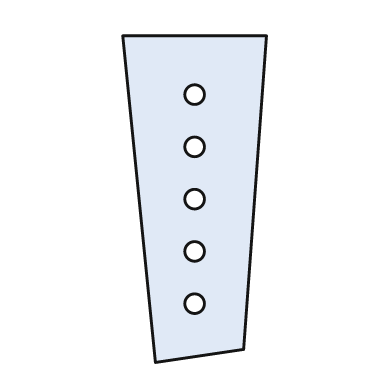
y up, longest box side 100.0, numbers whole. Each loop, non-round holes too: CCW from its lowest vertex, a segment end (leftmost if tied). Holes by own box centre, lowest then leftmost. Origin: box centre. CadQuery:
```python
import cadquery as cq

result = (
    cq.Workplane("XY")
    .moveTo(-12.0, -50.0)
    .lineTo(15.0, -46.0)
    .lineTo(22.0, 50.0)
    .lineTo(-22.0, 50.0)
    .close()
    .moveTo(0.0, -32.0)
    .circle(3.0)
    .moveTo(0.0, -16.0)
    .circle(3.0)
    .moveTo(0.0, 0.0)
    .circle(3.0)
    .moveTo(0.0, 16.0)
    .circle(3.0)
    .moveTo(0.0, 32.0)
    .circle(3.0)
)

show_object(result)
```